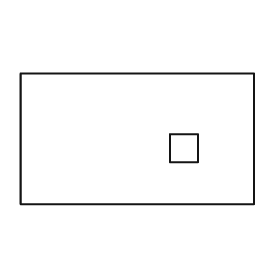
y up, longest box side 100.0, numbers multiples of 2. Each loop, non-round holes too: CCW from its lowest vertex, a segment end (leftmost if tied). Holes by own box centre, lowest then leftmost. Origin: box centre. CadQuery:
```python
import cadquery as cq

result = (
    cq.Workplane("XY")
    .moveTo(-50.0, -28.0)
    .lineTo(50.0, -28.0)
    .lineTo(50.0, 28.0)
    .lineTo(-50.0, 28.0)
    .close()
    .moveTo(14.0, -10.0)
    .lineTo(26.0, -10.0)
    .lineTo(26.0, 2.0)
    .lineTo(14.0, 2.0)
    .close()
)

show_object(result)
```